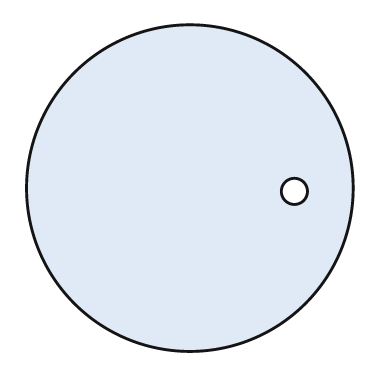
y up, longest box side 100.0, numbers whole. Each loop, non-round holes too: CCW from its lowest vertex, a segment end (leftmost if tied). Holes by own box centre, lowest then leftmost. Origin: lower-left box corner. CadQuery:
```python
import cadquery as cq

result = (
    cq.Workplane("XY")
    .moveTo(50.0, 50.0)
    .circle(50.0)
    .moveTo(82.0, 49.0)
    .circle(4.0)
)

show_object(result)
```